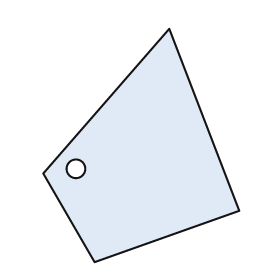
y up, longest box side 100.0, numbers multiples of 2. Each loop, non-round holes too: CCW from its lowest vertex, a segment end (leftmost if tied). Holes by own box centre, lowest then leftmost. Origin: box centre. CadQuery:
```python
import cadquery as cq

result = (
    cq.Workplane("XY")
    .moveTo(-20.0, -50.0)
    .lineTo(42.0, -28.0)
    .lineTo(12.0, 50.0)
    .lineTo(-42.0, -12.0)
    .close()
    .moveTo(-28.0, -10.0)
    .circle(4.0)
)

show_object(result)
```